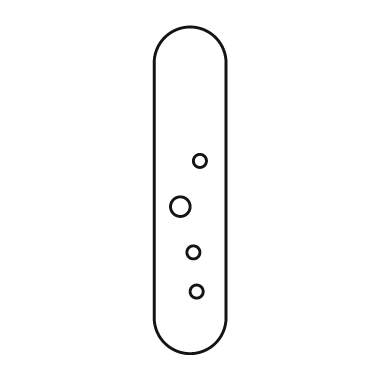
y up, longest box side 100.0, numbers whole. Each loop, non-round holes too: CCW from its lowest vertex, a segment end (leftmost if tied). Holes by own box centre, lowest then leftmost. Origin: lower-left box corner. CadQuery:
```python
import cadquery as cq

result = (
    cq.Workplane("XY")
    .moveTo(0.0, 11.0)
    .threePointArc((11.0, 0.0), (22.0, 11.0))
    .lineTo(22.0, 89.0)
    .threePointArc((11.0, 100.0), (0.0, 89.0))
    .close()
    .moveTo(13.0, 19.0)
    .circle(2.0)
    .moveTo(12.0, 31.0)
    .circle(2.0)
    .moveTo(8.0, 45.0)
    .circle(3.0)
    .moveTo(14.0, 59.0)
    .circle(2.0)
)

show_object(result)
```